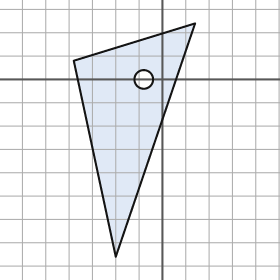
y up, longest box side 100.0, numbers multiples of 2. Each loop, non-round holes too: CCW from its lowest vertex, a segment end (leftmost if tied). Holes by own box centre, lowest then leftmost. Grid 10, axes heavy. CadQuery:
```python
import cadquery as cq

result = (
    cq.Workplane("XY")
    .moveTo(-20.0, -76.0)
    .lineTo(14.0, 24.0)
    .lineTo(-38.0, 8.0)
    .close()
    .moveTo(-8.0, 0.0)
    .circle(4.0)
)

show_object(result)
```